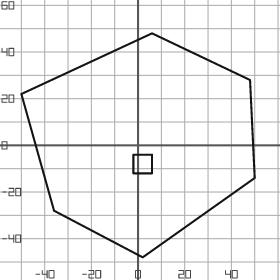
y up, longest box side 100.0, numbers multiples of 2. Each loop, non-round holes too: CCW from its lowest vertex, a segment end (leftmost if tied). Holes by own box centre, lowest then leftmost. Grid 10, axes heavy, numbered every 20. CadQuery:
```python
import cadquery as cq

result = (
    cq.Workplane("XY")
    .moveTo(2.0, -48.0)
    .lineTo(50.0, -14.0)
    .lineTo(48.0, 28.0)
    .lineTo(6.0, 48.0)
    .lineTo(-50.0, 22.0)
    .lineTo(-36.0, -28.0)
    .close()
    .moveTo(-2.0, -12.0)
    .lineTo(6.0, -12.0)
    .lineTo(6.0, -4.0)
    .lineTo(-2.0, -4.0)
    .close()
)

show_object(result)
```